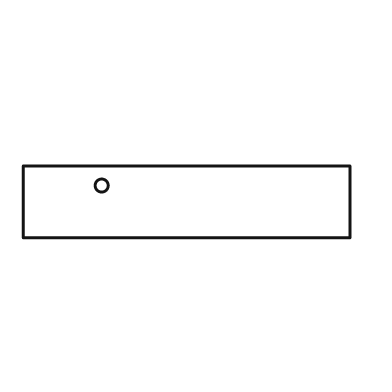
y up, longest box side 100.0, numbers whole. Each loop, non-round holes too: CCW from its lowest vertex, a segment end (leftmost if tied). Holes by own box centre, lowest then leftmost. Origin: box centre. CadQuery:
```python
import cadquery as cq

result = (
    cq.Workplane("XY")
    .moveTo(-50.0, -11.0)
    .lineTo(50.0, -11.0)
    .lineTo(50.0, 11.0)
    .lineTo(-50.0, 11.0)
    .close()
    .moveTo(-26.0, 5.0)
    .circle(2.0)
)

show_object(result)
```